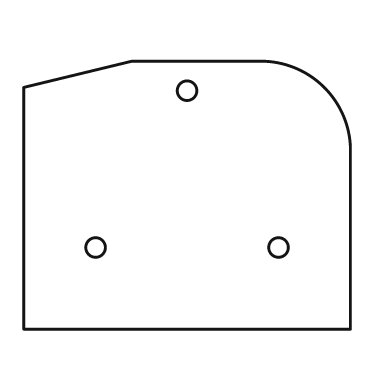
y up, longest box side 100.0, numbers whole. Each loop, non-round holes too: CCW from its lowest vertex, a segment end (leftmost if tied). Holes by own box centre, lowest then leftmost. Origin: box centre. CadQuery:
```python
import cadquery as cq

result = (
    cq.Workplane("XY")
    .moveTo(-50.0, -41.0)
    .lineTo(50.0, -41.0)
    .lineTo(50.0, 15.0)
    .threePointArc((42.0, 33.0), (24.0, 41.0))
    .lineTo(-17.0, 41.0)
    .lineTo(-50.0, 33.0)
    .close()
    .moveTo(-28.0, -16.0)
    .circle(3.0)
    .moveTo(28.0, -16.0)
    .circle(3.0)
    .moveTo(0.0, 32.0)
    .circle(3.0)
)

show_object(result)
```